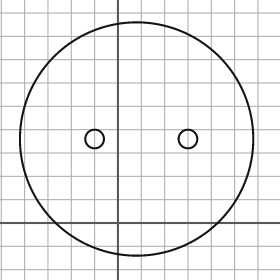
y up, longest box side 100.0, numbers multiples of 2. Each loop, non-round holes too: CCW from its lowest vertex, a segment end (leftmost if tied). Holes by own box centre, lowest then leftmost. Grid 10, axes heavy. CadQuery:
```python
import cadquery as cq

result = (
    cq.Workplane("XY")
    .moveTo(8.0, 36.0)
    .circle(50.0)
    .moveTo(-10.0, 36.0)
    .circle(4.0)
    .moveTo(30.0, 36.0)
    .circle(4.0)
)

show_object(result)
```